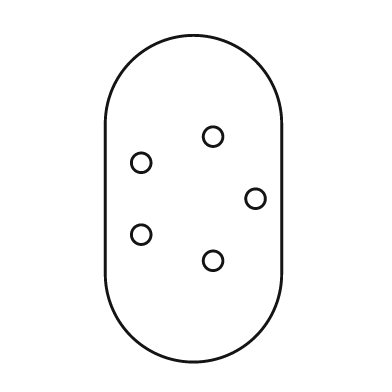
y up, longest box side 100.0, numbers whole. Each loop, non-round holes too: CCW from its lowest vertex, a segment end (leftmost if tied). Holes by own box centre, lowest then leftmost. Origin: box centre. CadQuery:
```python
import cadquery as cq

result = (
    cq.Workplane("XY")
    .moveTo(-27.0, -23.0)
    .threePointArc((0.0, -50.0), (27.0, -23.0))
    .lineTo(27.0, 23.0)
    .threePointArc((0.0, 50.0), (-27.0, 23.0))
    .close()
    .moveTo(6.0, -19.0)
    .circle(3.0)
    .moveTo(-16.0, -11.0)
    .circle(3.0)
    .moveTo(19.0, 0.0)
    .circle(3.0)
    .moveTo(-16.0, 11.0)
    .circle(3.0)
    .moveTo(6.0, 19.0)
    .circle(3.0)
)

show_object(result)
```